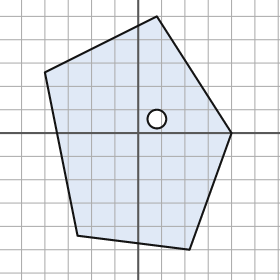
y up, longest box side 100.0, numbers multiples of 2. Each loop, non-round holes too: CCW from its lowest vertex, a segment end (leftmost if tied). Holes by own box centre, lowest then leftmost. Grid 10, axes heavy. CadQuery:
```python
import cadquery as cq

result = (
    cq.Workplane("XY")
    .moveTo(22.0, -50.0)
    .lineTo(40.0, 0.0)
    .lineTo(8.0, 50.0)
    .lineTo(-40.0, 26.0)
    .lineTo(-26.0, -44.0)
    .close()
    .moveTo(8.0, 6.0)
    .circle(4.0)
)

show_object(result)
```